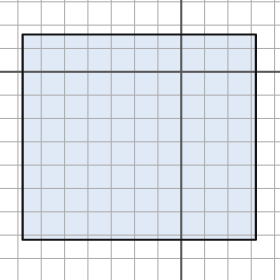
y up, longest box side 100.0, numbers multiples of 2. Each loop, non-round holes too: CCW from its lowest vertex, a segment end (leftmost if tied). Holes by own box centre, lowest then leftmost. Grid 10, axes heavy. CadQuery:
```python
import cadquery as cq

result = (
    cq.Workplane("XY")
    .moveTo(-68.0, -72.0)
    .lineTo(32.0, -72.0)
    .lineTo(32.0, 16.0)
    .lineTo(-68.0, 16.0)
    .close()
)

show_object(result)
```